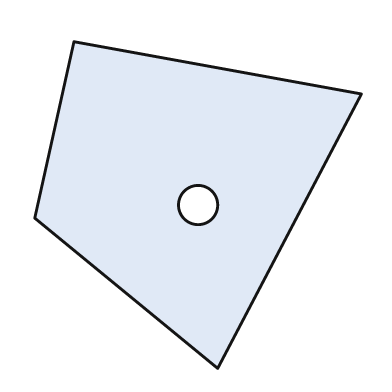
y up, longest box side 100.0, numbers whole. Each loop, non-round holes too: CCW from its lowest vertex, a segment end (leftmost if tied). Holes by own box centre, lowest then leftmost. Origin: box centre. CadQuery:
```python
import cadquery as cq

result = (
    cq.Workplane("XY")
    .moveTo(6.0, -50.0)
    .lineTo(50.0, 34.0)
    .lineTo(-38.0, 50.0)
    .lineTo(-50.0, -4.0)
    .close()
    .moveTo(0.0, 0.0)
    .circle(6.0)
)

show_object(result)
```